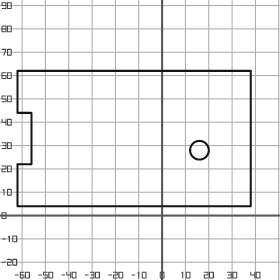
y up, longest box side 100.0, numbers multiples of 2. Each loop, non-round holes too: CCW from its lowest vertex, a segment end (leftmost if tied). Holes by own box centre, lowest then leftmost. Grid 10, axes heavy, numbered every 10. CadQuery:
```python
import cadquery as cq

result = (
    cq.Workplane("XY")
    .moveTo(-62.0, 4.0)
    .lineTo(38.0, 4.0)
    .lineTo(38.0, 62.0)
    .lineTo(-62.0, 62.0)
    .lineTo(-62.0, 44.0)
    .lineTo(-56.0, 44.0)
    .lineTo(-56.0, 22.0)
    .lineTo(-62.0, 22.0)
    .close()
    .moveTo(16.0, 28.0)
    .circle(4.0)
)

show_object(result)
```